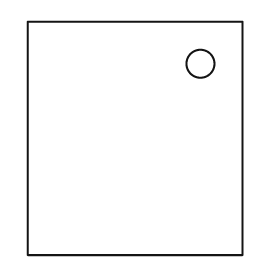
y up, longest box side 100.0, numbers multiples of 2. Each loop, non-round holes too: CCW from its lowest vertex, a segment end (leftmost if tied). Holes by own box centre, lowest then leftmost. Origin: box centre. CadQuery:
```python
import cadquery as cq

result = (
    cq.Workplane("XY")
    .moveTo(-46.0, -50.0)
    .lineTo(46.0, -50.0)
    .lineTo(46.0, 50.0)
    .lineTo(-46.0, 50.0)
    .close()
    .moveTo(28.0, 32.0)
    .circle(6.0)
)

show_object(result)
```